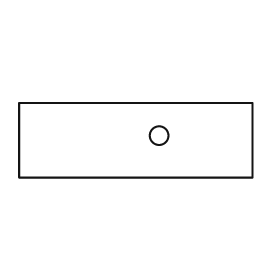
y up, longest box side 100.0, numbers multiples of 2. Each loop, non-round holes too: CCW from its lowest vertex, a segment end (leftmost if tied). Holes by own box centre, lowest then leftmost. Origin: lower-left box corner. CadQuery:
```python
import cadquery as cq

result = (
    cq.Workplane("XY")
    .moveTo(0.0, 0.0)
    .lineTo(100.0, 0.0)
    .lineTo(100.0, 32.0)
    .lineTo(0.0, 32.0)
    .close()
    .moveTo(60.0, 18.0)
    .circle(4.0)
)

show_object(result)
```